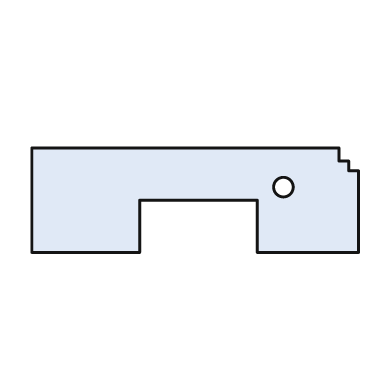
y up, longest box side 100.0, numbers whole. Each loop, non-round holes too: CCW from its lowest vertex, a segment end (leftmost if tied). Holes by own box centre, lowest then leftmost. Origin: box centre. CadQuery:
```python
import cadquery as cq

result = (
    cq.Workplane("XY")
    .moveTo(-50.0, -16.0)
    .lineTo(-17.0, -16.0)
    .lineTo(-17.0, 0.0)
    .lineTo(19.0, 0.0)
    .lineTo(19.0, -16.0)
    .lineTo(50.0, -16.0)
    .lineTo(50.0, 9.0)
    .lineTo(47.0, 9.0)
    .lineTo(47.0, 12.0)
    .lineTo(44.0, 12.0)
    .lineTo(44.0, 16.0)
    .lineTo(-50.0, 16.0)
    .close()
    .moveTo(27.0, 4.0)
    .circle(3.0)
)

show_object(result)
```